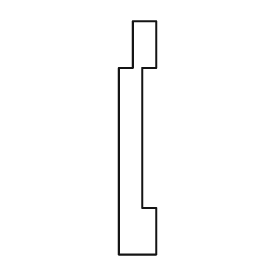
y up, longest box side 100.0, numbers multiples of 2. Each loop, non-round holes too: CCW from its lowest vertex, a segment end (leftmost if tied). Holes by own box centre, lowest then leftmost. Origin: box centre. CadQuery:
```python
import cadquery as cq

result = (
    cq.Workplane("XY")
    .moveTo(-8.0, -50.0)
    .lineTo(8.0, -50.0)
    .lineTo(8.0, -30.0)
    .lineTo(2.0, -30.0)
    .lineTo(2.0, 30.0)
    .lineTo(8.0, 30.0)
    .lineTo(8.0, 50.0)
    .lineTo(-2.0, 50.0)
    .lineTo(-2.0, 30.0)
    .lineTo(-8.0, 30.0)
    .close()
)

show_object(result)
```